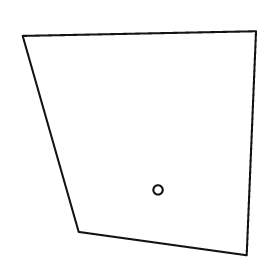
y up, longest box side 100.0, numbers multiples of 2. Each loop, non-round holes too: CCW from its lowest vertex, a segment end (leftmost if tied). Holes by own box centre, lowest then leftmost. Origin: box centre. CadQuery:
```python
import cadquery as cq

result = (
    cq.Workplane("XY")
    .moveTo(46.0, -48.0)
    .lineTo(50.0, 48.0)
    .lineTo(-50.0, 46.0)
    .lineTo(-26.0, -38.0)
    .close()
    .moveTo(8.0, -20.0)
    .circle(2.0)
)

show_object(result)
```